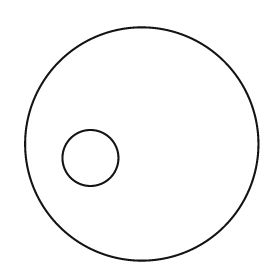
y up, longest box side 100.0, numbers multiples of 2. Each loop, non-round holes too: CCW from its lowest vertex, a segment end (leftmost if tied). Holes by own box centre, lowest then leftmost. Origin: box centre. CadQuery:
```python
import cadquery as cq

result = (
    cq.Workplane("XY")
    .moveTo(0.0, 0.0)
    .circle(50.0)
    .moveTo(-22.0, -6.0)
    .circle(12.0)
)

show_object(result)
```